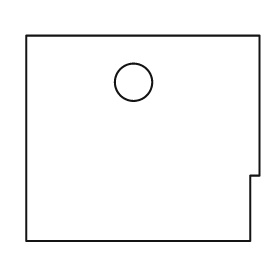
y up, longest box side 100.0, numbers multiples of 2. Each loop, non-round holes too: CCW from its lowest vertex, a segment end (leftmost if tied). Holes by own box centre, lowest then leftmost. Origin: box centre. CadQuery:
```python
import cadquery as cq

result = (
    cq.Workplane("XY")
    .moveTo(-50.0, -44.0)
    .lineTo(46.0, -44.0)
    .lineTo(46.0, -16.0)
    .lineTo(50.0, -16.0)
    .lineTo(50.0, 44.0)
    .lineTo(-50.0, 44.0)
    .close()
    .moveTo(-4.0, 24.0)
    .circle(8.0)
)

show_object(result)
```